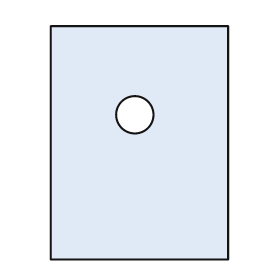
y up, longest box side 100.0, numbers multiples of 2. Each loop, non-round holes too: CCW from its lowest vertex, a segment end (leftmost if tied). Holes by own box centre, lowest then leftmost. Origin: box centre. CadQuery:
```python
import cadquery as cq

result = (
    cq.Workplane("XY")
    .moveTo(-38.0, -50.0)
    .lineTo(38.0, -50.0)
    .lineTo(38.0, 50.0)
    .lineTo(-38.0, 50.0)
    .close()
    .moveTo(-2.0, 12.0)
    .circle(8.0)
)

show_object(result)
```